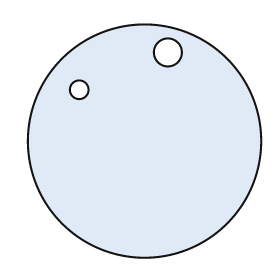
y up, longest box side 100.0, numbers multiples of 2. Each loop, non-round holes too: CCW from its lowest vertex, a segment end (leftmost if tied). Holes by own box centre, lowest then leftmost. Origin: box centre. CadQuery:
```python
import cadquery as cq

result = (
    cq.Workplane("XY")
    .moveTo(0.0, 0.0)
    .circle(50.0)
    .moveTo(-28.0, 22.0)
    .circle(4.0)
    .moveTo(10.0, 38.0)
    .circle(6.0)
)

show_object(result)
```